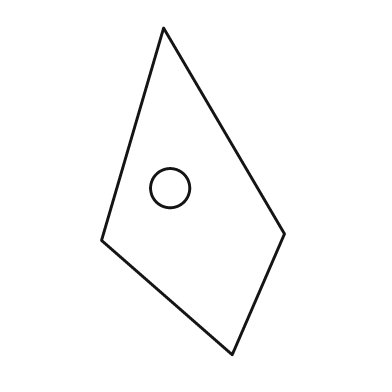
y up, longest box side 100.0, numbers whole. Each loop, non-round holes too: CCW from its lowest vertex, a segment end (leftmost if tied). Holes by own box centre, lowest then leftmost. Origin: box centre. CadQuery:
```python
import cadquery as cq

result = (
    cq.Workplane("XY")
    .moveTo(12.0, -50.0)
    .lineTo(28.0, -13.0)
    .lineTo(-9.0, 50.0)
    .lineTo(-28.0, -15.0)
    .close()
    .moveTo(-7.0, 1.0)
    .circle(6.0)
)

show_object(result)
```